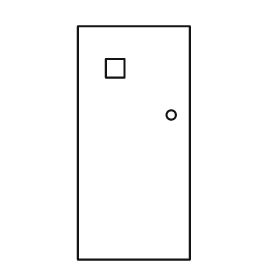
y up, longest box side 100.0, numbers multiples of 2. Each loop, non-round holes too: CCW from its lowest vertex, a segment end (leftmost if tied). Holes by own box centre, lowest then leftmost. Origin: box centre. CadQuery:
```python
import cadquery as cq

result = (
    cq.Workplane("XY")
    .moveTo(-24.0, -50.0)
    .lineTo(24.0, -50.0)
    .lineTo(24.0, 50.0)
    .lineTo(-24.0, 50.0)
    .close()
    .moveTo(16.0, 12.0)
    .circle(2.0)
    .moveTo(-12.0, 28.0)
    .lineTo(-4.0, 28.0)
    .lineTo(-4.0, 36.0)
    .lineTo(-12.0, 36.0)
    .close()
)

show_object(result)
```